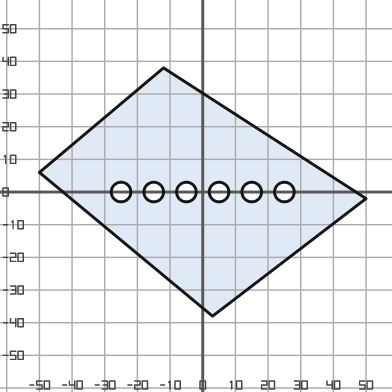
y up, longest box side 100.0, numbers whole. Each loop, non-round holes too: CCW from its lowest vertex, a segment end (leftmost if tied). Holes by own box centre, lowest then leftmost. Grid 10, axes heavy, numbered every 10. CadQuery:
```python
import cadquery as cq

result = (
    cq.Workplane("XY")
    .moveTo(3.0, -38.0)
    .lineTo(50.0, -2.0)
    .lineTo(-12.0, 38.0)
    .lineTo(-50.0, 6.0)
    .close()
    .moveTo(-25.0, 0.0)
    .circle(3.0)
    .moveTo(-15.0, 0.0)
    .circle(3.0)
    .moveTo(-5.0, 0.0)
    .circle(3.0)
    .moveTo(5.0, 0.0)
    .circle(3.0)
    .moveTo(15.0, 0.0)
    .circle(3.0)
    .moveTo(25.0, 0.0)
    .circle(3.0)
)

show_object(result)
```